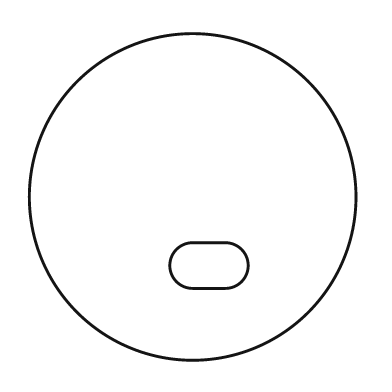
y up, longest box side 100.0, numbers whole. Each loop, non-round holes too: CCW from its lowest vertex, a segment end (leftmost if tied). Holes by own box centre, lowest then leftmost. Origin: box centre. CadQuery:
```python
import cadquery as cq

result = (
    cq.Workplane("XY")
    .moveTo(0.0, 0.0)
    .circle(50.0)
    .moveTo(0.0, -28.0)
    .lineTo(10.0, -28.0)
    .threePointArc((17.0, -21.0), (10.0, -14.0))
    .lineTo(0.0, -14.0)
    .threePointArc((-7.0, -21.0), (0.0, -28.0))
    .close()
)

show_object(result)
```